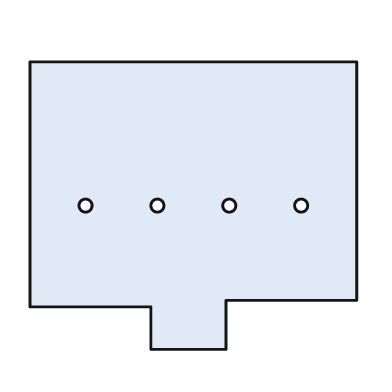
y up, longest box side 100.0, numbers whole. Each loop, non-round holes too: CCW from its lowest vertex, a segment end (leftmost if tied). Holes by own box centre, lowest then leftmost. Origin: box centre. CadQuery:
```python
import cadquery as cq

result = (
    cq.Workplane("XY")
    .moveTo(-13.0, -44.0)
    .lineTo(10.0, -44.0)
    .lineTo(10.0, -29.0)
    .lineTo(50.0, -29.0)
    .lineTo(50.0, 44.0)
    .lineTo(-50.0, 44.0)
    .lineTo(-50.0, -31.0)
    .lineTo(-13.0, -31.0)
    .close()
    .moveTo(-33.0, 0.0)
    .circle(2.0)
    .moveTo(-11.0, 0.0)
    .circle(2.0)
    .moveTo(11.0, 0.0)
    .circle(2.0)
    .moveTo(33.0, 0.0)
    .circle(2.0)
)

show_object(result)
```